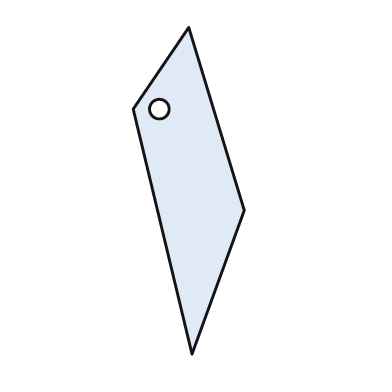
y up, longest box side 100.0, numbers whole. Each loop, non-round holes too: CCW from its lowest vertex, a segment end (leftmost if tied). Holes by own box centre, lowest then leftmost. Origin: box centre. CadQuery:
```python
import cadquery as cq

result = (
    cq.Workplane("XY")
    .moveTo(1.0, -50.0)
    .lineTo(17.0, -6.0)
    .lineTo(0.0, 50.0)
    .lineTo(-17.0, 25.0)
    .close()
    .moveTo(-9.0, 25.0)
    .circle(3.0)
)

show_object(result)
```